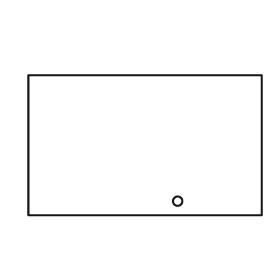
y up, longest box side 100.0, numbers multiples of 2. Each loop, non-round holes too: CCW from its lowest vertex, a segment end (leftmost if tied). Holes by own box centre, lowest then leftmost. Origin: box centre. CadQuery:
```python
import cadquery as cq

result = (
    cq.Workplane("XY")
    .moveTo(-50.0, -30.0)
    .lineTo(50.0, -30.0)
    .lineTo(50.0, 30.0)
    .lineTo(-50.0, 30.0)
    .close()
    .moveTo(14.0, -24.0)
    .circle(2.0)
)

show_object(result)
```